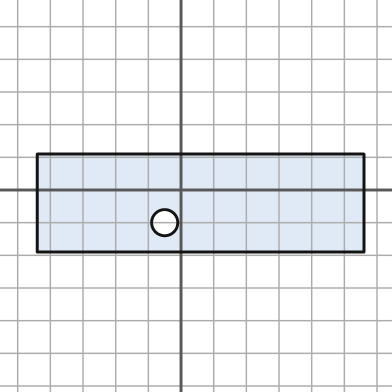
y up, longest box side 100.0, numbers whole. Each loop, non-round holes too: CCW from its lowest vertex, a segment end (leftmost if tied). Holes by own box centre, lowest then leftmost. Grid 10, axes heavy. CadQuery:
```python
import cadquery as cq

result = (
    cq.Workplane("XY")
    .moveTo(-44.0, -19.0)
    .lineTo(56.0, -19.0)
    .lineTo(56.0, 11.0)
    .lineTo(-44.0, 11.0)
    .close()
    .moveTo(-5.0, -10.0)
    .circle(4.0)
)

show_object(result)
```